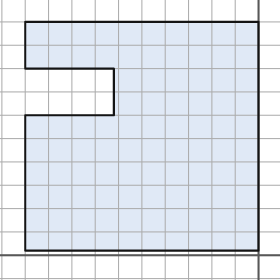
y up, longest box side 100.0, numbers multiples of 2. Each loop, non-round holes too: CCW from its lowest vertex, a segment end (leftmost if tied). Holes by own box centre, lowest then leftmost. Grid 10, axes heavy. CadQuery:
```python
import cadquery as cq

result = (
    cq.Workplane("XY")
    .moveTo(-100.0, 2.0)
    .lineTo(0.0, 2.0)
    .lineTo(0.0, 100.0)
    .lineTo(-100.0, 100.0)
    .lineTo(-100.0, 80.0)
    .lineTo(-62.0, 80.0)
    .lineTo(-62.0, 60.0)
    .lineTo(-100.0, 60.0)
    .close()
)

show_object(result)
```